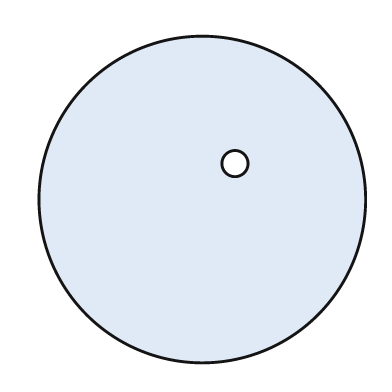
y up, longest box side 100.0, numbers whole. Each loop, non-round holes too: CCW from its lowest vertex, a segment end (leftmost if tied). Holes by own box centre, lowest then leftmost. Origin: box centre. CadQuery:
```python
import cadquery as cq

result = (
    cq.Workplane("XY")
    .moveTo(0.0, 0.0)
    .circle(50.0)
    .moveTo(10.0, 11.0)
    .circle(4.0)
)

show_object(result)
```